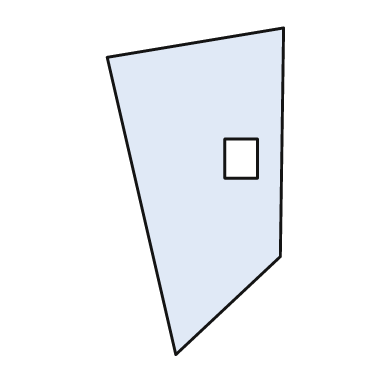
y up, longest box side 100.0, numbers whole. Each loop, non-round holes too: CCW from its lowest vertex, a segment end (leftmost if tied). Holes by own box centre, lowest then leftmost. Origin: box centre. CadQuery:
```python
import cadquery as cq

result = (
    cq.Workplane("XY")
    .moveTo(-6.0, -50.0)
    .lineTo(26.0, -20.0)
    .lineTo(27.0, 50.0)
    .lineTo(-27.0, 41.0)
    .close()
    .moveTo(9.0, 4.0)
    .lineTo(19.0, 4.0)
    .lineTo(19.0, 16.0)
    .lineTo(9.0, 16.0)
    .close()
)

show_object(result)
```